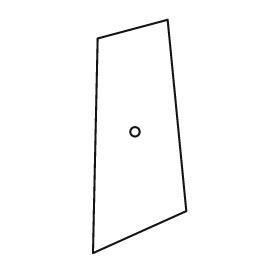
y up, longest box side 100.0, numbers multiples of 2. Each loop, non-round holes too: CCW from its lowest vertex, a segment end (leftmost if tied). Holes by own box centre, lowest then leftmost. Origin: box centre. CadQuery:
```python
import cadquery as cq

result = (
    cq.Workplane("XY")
    .moveTo(-20.0, -50.0)
    .lineTo(20.0, -32.0)
    .lineTo(12.0, 50.0)
    .lineTo(-18.0, 42.0)
    .close()
    .moveTo(-2.0, 2.0)
    .circle(2.0)
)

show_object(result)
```